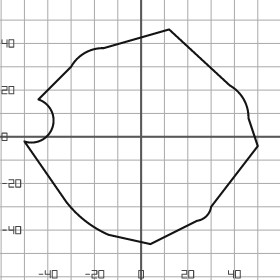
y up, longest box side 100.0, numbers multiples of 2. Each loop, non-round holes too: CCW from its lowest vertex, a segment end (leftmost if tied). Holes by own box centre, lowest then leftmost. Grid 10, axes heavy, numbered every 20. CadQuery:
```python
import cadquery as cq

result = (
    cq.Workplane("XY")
    .moveTo(4.0, -46.0)
    .lineTo(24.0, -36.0)
    .threePointArc((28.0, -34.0), (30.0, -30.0))
    .lineTo(50.0, -4.0)
    .lineTo(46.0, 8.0)
    .threePointArc((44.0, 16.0), (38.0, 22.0))
    .lineTo(12.0, 46.0)
    .lineTo(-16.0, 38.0)
    .threePointArc((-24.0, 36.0), (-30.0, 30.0))
    .lineTo(-44.0, 16.0)
    .threePointArc((-38.0, 4.0), (-50.0, -2.0))
    .lineTo(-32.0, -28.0)
    .threePointArc((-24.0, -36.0), (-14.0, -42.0))
    .close()
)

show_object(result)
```